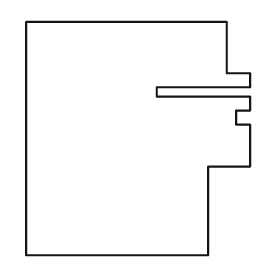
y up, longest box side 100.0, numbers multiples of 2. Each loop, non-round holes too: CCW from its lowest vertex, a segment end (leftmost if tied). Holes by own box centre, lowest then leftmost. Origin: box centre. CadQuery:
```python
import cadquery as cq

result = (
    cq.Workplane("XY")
    .moveTo(-48.0, -50.0)
    .lineTo(30.0, -50.0)
    .lineTo(30.0, -12.0)
    .lineTo(48.0, -12.0)
    .lineTo(48.0, 6.0)
    .lineTo(42.0, 6.0)
    .lineTo(42.0, 12.0)
    .lineTo(48.0, 12.0)
    .lineTo(48.0, 18.0)
    .lineTo(8.0, 18.0)
    .lineTo(8.0, 22.0)
    .lineTo(48.0, 22.0)
    .lineTo(48.0, 28.0)
    .lineTo(38.0, 28.0)
    .lineTo(38.0, 50.0)
    .lineTo(-48.0, 50.0)
    .close()
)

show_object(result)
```